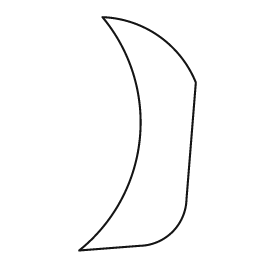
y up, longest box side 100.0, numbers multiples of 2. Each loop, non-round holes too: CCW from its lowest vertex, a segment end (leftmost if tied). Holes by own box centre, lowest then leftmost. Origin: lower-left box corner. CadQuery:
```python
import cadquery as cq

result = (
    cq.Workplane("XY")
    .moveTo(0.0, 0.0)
    .lineTo(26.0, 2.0)
    .threePointArc((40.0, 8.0), (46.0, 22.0))
    .lineTo(50.0, 72.0)
    .threePointArc((34.0, 92.0), (10.0, 100.0))
    .threePointArc((26.0, 48.0), (0.0, 0.0))
    .close()
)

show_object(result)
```